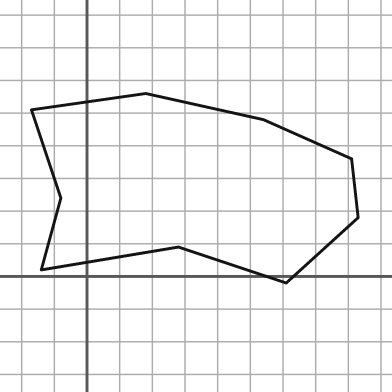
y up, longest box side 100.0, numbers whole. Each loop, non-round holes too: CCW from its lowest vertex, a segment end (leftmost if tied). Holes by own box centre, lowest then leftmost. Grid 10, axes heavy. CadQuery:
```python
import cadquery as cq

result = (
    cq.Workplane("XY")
    .moveTo(61.0, -2.0)
    .lineTo(83.0, 18.0)
    .lineTo(81.0, 36.0)
    .lineTo(54.0, 48.0)
    .lineTo(18.0, 56.0)
    .lineTo(-17.0, 51.0)
    .lineTo(-8.0, 24.0)
    .lineTo(-14.0, 2.0)
    .lineTo(28.0, 9.0)
    .close()
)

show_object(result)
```